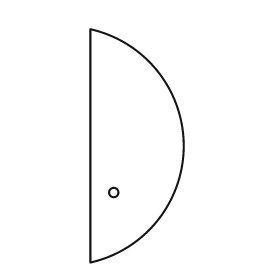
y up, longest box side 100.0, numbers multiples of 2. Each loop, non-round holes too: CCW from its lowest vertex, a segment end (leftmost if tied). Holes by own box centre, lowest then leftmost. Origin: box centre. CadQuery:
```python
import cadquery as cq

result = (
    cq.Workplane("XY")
    .moveTo(-20.0, -50.0)
    .threePointArc((20.0, 0.0), (-20.0, 50.0))
    .close()
    .moveTo(-10.0, -20.0)
    .circle(2.0)
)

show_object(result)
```